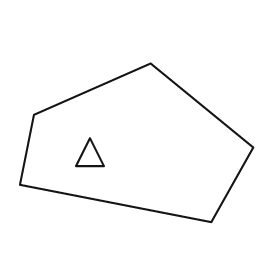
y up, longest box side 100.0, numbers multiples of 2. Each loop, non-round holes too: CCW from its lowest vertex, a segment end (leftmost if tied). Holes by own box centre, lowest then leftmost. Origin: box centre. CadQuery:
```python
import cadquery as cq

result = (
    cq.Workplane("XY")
    .moveTo(32.0, -34.0)
    .lineTo(50.0, -2.0)
    .lineTo(6.0, 34.0)
    .lineTo(-44.0, 12.0)
    .lineTo(-50.0, -18.0)
    .close()
    .moveTo(-26.0, -10.0)
    .lineTo(-14.0, -10.0)
    .lineTo(-20.0, 2.0)
    .close()
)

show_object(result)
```